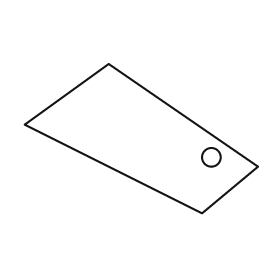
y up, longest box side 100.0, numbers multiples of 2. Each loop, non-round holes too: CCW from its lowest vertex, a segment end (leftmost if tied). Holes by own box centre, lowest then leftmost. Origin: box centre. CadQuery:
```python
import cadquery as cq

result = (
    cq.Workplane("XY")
    .moveTo(26.0, -32.0)
    .lineTo(50.0, -12.0)
    .lineTo(-14.0, 32.0)
    .lineTo(-50.0, 6.0)
    .close()
    .moveTo(30.0, -8.0)
    .circle(4.0)
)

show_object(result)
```